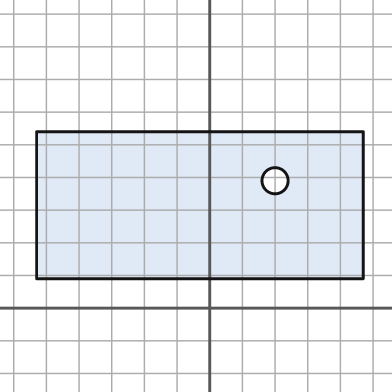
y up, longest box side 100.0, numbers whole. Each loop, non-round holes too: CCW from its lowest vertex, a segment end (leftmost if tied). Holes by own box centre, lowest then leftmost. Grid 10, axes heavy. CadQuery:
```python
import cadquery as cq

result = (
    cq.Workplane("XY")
    .moveTo(-53.0, 9.0)
    .lineTo(47.0, 9.0)
    .lineTo(47.0, 54.0)
    .lineTo(-53.0, 54.0)
    .close()
    .moveTo(20.0, 39.0)
    .circle(4.0)
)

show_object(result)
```